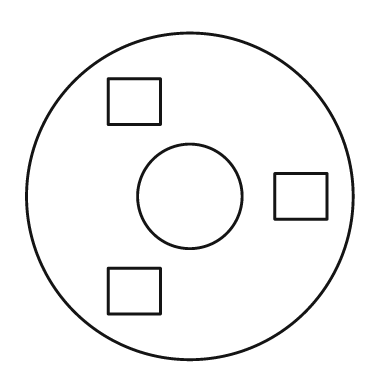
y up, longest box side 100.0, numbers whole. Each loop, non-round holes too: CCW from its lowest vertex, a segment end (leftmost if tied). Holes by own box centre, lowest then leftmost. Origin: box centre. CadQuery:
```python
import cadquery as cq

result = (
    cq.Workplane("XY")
    .moveTo(0.0, 0.0)
    .circle(50.0)
    .moveTo(-25.0, -36.0)
    .lineTo(-9.0, -36.0)
    .lineTo(-9.0, -22.0)
    .lineTo(-25.0, -22.0)
    .close()
    .moveTo(0.0, 0.0)
    .circle(16.0)
    .moveTo(26.0, -7.0)
    .lineTo(42.0, -7.0)
    .lineTo(42.0, 7.0)
    .lineTo(26.0, 7.0)
    .close()
    .moveTo(-25.0, 22.0)
    .lineTo(-9.0, 22.0)
    .lineTo(-9.0, 36.0)
    .lineTo(-25.0, 36.0)
    .close()
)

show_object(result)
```